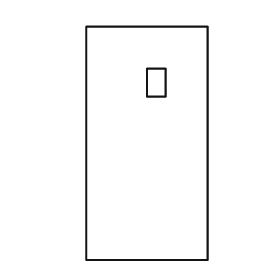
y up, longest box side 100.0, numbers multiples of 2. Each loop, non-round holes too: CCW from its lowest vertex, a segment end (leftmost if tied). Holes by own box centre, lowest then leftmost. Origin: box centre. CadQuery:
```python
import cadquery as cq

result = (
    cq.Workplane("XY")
    .moveTo(-26.0, -50.0)
    .lineTo(26.0, -50.0)
    .lineTo(26.0, 50.0)
    .lineTo(-26.0, 50.0)
    .close()
    .moveTo(0.0, 20.0)
    .lineTo(8.0, 20.0)
    .lineTo(8.0, 32.0)
    .lineTo(0.0, 32.0)
    .close()
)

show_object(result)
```